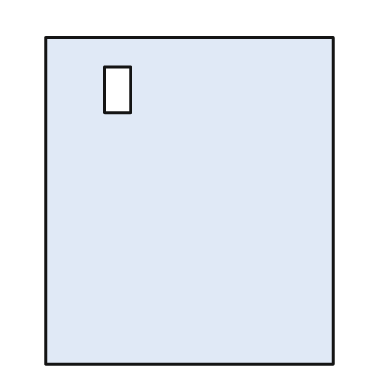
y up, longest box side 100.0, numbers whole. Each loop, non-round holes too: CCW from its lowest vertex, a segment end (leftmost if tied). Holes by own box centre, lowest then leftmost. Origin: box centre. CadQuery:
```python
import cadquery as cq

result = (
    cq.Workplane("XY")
    .moveTo(-44.0, -50.0)
    .lineTo(44.0, -50.0)
    .lineTo(44.0, 50.0)
    .lineTo(-44.0, 50.0)
    .close()
    .moveTo(-26.0, 27.0)
    .lineTo(-18.0, 27.0)
    .lineTo(-18.0, 41.0)
    .lineTo(-26.0, 41.0)
    .close()
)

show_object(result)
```